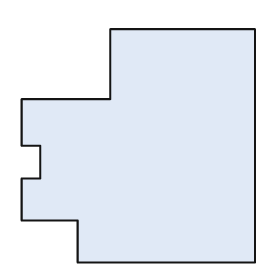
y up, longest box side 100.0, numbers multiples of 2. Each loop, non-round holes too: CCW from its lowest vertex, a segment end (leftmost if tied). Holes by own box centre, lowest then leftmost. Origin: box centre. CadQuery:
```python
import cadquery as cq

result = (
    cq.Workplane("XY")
    .moveTo(-26.0, -50.0)
    .lineTo(50.0, -50.0)
    .lineTo(50.0, 50.0)
    .lineTo(-12.0, 50.0)
    .lineTo(-12.0, 20.0)
    .lineTo(-50.0, 20.0)
    .lineTo(-50.0, 0.0)
    .lineTo(-42.0, 0.0)
    .lineTo(-42.0, -14.0)
    .lineTo(-50.0, -14.0)
    .lineTo(-50.0, -32.0)
    .lineTo(-26.0, -32.0)
    .close()
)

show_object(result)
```